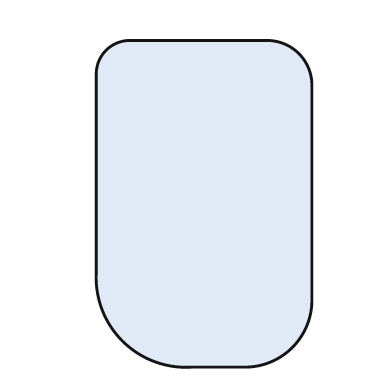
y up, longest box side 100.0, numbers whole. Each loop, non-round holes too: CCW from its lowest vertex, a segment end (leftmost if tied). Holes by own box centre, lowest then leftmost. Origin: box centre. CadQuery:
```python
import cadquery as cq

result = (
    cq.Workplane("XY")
    .moveTo(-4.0, -50.0)
    .lineTo(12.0, -50.0)
    .threePointArc((27.0, -44.0), (33.0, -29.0))
    .lineTo(33.0, 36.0)
    .threePointArc((29.0, 46.0), (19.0, 50.0))
    .lineTo(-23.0, 50.0)
    .threePointArc((-30.0, 47.0), (-33.0, 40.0))
    .lineTo(-33.0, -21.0)
    .threePointArc((-25.0, -42.0), (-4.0, -50.0))
    .close()
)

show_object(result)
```